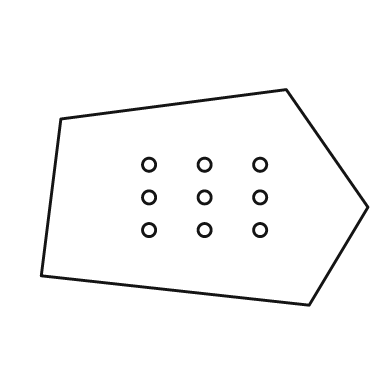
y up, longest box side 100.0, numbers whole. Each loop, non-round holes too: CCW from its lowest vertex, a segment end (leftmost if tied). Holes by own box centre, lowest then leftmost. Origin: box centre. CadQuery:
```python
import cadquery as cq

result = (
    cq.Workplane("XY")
    .moveTo(32.0, -33.0)
    .lineTo(50.0, -3.0)
    .lineTo(25.0, 33.0)
    .lineTo(-44.0, 24.0)
    .lineTo(-50.0, -24.0)
    .close()
    .moveTo(-17.0, -10.0)
    .circle(2.0)
    .moveTo(0.0, -10.0)
    .circle(2.0)
    .moveTo(17.0, -10.0)
    .circle(2.0)
    .moveTo(-17.0, 0.0)
    .circle(2.0)
    .moveTo(0.0, 0.0)
    .circle(2.0)
    .moveTo(17.0, 0.0)
    .circle(2.0)
    .moveTo(-17.0, 10.0)
    .circle(2.0)
    .moveTo(0.0, 10.0)
    .circle(2.0)
    .moveTo(17.0, 10.0)
    .circle(2.0)
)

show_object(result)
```